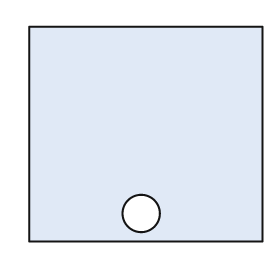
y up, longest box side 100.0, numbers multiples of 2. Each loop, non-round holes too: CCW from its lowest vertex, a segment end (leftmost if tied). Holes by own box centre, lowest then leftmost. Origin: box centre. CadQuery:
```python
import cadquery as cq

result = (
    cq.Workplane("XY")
    .moveTo(-50.0, -46.0)
    .lineTo(50.0, -46.0)
    .lineTo(50.0, 46.0)
    .lineTo(-50.0, 46.0)
    .close()
    .moveTo(-2.0, -34.0)
    .circle(8.0)
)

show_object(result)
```